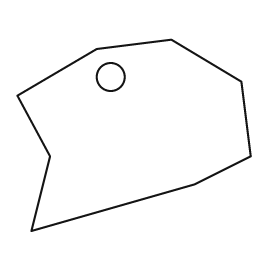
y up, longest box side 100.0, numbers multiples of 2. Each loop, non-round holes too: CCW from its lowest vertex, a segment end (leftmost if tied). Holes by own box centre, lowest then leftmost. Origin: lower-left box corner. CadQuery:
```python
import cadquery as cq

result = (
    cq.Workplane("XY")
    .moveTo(6.0, 0.0)
    .lineTo(76.0, 20.0)
    .lineTo(100.0, 32.0)
    .lineTo(96.0, 64.0)
    .lineTo(66.0, 82.0)
    .lineTo(34.0, 78.0)
    .lineTo(0.0, 58.0)
    .lineTo(14.0, 32.0)
    .close()
    .moveTo(40.0, 66.0)
    .circle(6.0)
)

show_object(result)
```